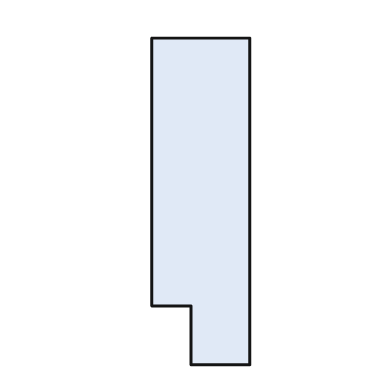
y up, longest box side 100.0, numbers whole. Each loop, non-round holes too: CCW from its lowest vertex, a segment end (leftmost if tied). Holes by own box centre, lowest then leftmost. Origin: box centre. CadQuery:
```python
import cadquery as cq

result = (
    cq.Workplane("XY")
    .moveTo(-3.0, -50.0)
    .lineTo(15.0, -50.0)
    .lineTo(15.0, 50.0)
    .lineTo(-15.0, 50.0)
    .lineTo(-15.0, -32.0)
    .lineTo(-3.0, -32.0)
    .close()
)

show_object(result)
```